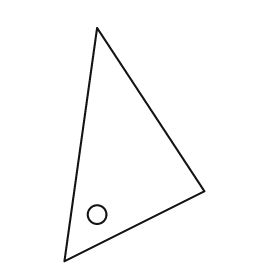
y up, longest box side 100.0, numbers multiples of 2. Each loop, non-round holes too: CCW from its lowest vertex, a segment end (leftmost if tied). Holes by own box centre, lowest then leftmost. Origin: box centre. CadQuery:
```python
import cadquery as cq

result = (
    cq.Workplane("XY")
    .moveTo(-30.0, -50.0)
    .lineTo(30.0, -20.0)
    .lineTo(-16.0, 50.0)
    .close()
    .moveTo(-16.0, -30.0)
    .circle(4.0)
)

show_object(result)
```